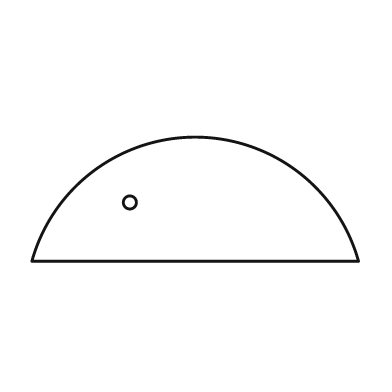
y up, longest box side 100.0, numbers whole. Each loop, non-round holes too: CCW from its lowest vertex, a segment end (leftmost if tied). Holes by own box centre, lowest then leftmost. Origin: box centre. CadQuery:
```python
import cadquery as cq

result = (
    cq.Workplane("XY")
    .moveTo(-50.0, -19.0)
    .lineTo(50.0, -19.0)
    .threePointArc((0.0, 19.0), (-50.0, -19.0))
    .close()
    .moveTo(-20.0, -1.0)
    .circle(2.0)
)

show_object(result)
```